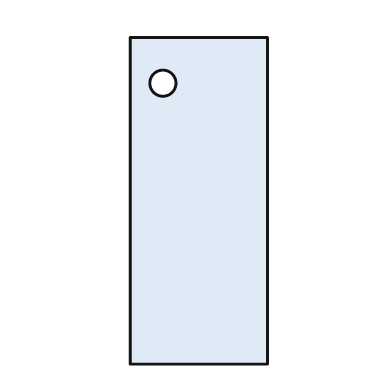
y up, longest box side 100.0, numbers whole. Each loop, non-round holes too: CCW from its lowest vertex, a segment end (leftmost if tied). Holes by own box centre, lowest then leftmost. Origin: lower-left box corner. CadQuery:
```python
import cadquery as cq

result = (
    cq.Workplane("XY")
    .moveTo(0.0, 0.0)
    .lineTo(42.0, 0.0)
    .lineTo(42.0, 100.0)
    .lineTo(0.0, 100.0)
    .close()
    .moveTo(10.0, 86.0)
    .circle(4.0)
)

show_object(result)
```